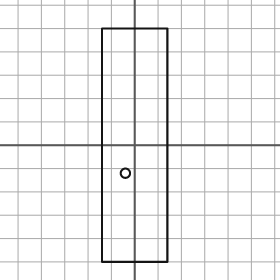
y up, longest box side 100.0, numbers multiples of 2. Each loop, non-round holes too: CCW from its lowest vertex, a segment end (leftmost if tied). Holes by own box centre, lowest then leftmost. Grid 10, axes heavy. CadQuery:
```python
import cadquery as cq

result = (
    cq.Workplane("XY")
    .moveTo(-14.0, -50.0)
    .lineTo(14.0, -50.0)
    .lineTo(14.0, 50.0)
    .lineTo(-14.0, 50.0)
    .close()
    .moveTo(-4.0, -12.0)
    .circle(2.0)
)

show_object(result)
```